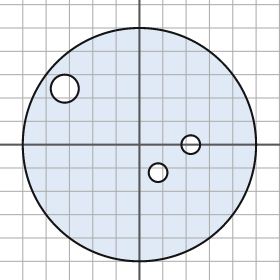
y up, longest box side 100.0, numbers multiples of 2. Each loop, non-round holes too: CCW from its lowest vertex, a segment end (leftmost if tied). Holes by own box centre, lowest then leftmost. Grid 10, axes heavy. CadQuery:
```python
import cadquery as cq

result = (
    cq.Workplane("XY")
    .moveTo(0.0, 0.0)
    .circle(50.0)
    .moveTo(8.0, -12.0)
    .circle(4.0)
    .moveTo(22.0, 0.0)
    .circle(4.0)
    .moveTo(-32.0, 24.0)
    .circle(6.0)
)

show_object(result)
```